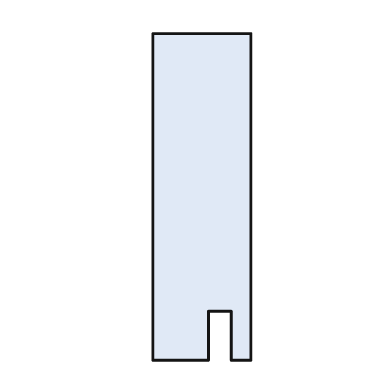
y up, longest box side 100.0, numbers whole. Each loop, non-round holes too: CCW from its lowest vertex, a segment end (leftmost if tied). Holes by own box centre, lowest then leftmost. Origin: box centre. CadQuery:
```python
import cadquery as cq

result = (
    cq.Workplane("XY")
    .moveTo(-15.0, -50.0)
    .lineTo(2.0, -50.0)
    .lineTo(2.0, -35.0)
    .lineTo(9.0, -35.0)
    .lineTo(9.0, -50.0)
    .lineTo(15.0, -50.0)
    .lineTo(15.0, 50.0)
    .lineTo(-15.0, 50.0)
    .close()
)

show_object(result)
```